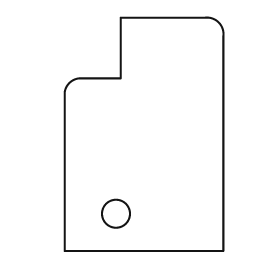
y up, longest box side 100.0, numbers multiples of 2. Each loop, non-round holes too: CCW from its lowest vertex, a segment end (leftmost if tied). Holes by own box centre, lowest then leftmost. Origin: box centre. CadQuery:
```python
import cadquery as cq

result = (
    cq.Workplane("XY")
    .moveTo(-34.0, -50.0)
    .lineTo(34.0, -50.0)
    .lineTo(34.0, 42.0)
    .threePointArc((32.0, 48.0), (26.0, 50.0))
    .lineTo(-10.0, 50.0)
    .lineTo(-10.0, 24.0)
    .lineTo(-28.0, 24.0)
    .threePointArc((-32.0, 22.0), (-34.0, 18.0))
    .close()
    .moveTo(-12.0, -34.0)
    .circle(6.0)
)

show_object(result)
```